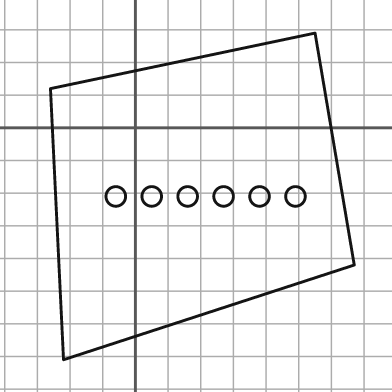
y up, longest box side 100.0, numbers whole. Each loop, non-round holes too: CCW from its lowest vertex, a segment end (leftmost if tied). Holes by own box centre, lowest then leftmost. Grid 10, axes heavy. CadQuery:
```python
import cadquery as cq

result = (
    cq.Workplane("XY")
    .moveTo(-22.0, -71.0)
    .lineTo(67.0, -42.0)
    .lineTo(55.0, 29.0)
    .lineTo(-26.0, 12.0)
    .close()
    .moveTo(-6.0, -21.0)
    .circle(3.0)
    .moveTo(5.0, -21.0)
    .circle(3.0)
    .moveTo(16.0, -21.0)
    .circle(3.0)
    .moveTo(27.0, -21.0)
    .circle(3.0)
    .moveTo(38.0, -21.0)
    .circle(3.0)
    .moveTo(49.0, -21.0)
    .circle(3.0)
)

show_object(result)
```